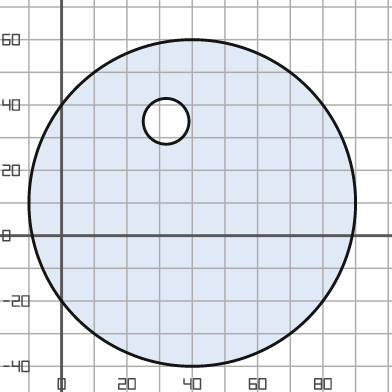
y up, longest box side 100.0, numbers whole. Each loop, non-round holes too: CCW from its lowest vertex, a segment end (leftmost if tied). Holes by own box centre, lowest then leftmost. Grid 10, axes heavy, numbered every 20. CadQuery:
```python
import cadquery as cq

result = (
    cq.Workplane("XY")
    .moveTo(40.0, 10.0)
    .circle(50.0)
    .moveTo(32.0, 35.0)
    .circle(7.0)
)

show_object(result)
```